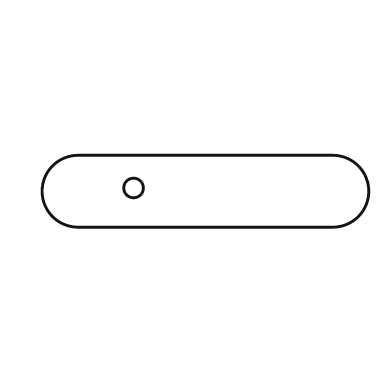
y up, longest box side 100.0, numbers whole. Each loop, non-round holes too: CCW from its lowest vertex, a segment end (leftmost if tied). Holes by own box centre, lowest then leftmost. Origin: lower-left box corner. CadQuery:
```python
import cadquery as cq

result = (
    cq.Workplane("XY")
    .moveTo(11.0, 0.0)
    .lineTo(89.0, 0.0)
    .threePointArc((100.0, 11.0), (89.0, 22.0))
    .lineTo(11.0, 22.0)
    .threePointArc((0.0, 11.0), (11.0, 0.0))
    .close()
    .moveTo(28.0, 12.0)
    .circle(3.0)
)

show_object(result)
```